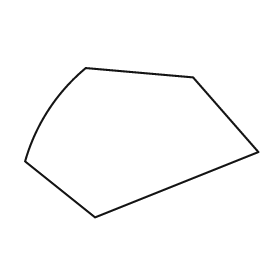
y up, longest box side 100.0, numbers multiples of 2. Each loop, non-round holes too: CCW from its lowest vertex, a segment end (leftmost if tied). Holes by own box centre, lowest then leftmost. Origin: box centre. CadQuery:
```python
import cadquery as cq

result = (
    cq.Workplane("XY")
    .moveTo(-20.0, -32.0)
    .lineTo(50.0, -4.0)
    .lineTo(22.0, 28.0)
    .lineTo(-24.0, 32.0)
    .threePointArc((-40.0, 14.0), (-50.0, -8.0))
    .close()
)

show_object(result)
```